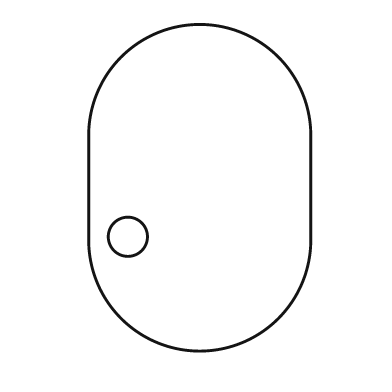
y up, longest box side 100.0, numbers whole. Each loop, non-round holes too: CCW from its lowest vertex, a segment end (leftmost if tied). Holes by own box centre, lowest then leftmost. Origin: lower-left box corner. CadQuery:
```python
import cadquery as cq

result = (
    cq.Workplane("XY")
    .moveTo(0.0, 34.0)
    .threePointArc((34.0, 0.0), (68.0, 34.0))
    .lineTo(68.0, 66.0)
    .threePointArc((34.0, 100.0), (0.0, 66.0))
    .close()
    .moveTo(12.0, 35.0)
    .circle(6.0)
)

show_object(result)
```